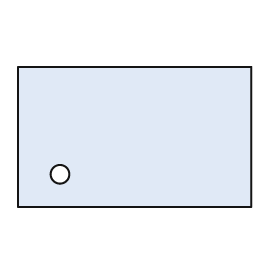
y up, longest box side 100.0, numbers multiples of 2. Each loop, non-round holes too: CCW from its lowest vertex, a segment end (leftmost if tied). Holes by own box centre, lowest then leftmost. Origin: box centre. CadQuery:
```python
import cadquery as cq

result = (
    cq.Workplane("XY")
    .moveTo(-50.0, -30.0)
    .lineTo(50.0, -30.0)
    .lineTo(50.0, 30.0)
    .lineTo(-50.0, 30.0)
    .close()
    .moveTo(-32.0, -16.0)
    .circle(4.0)
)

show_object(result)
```